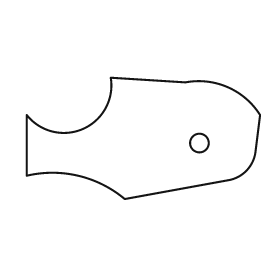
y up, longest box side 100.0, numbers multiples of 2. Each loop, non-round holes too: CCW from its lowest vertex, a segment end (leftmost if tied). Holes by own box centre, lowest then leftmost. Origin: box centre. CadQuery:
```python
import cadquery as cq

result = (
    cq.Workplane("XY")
    .moveTo(-8.0, -26.0)
    .lineTo(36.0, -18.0)
    .threePointArc((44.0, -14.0), (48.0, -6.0))
    .lineTo(50.0, 10.0)
    .threePointArc((36.0, 22.0), (18.0, 24.0))
    .lineTo(-14.0, 26.0)
    .threePointArc((-26.0, 4.0), (-50.0, 10.0))
    .lineTo(-50.0, -16.0)
    .threePointArc((-28.0, -16.0), (-8.0, -26.0))
    .close()
    .moveTo(24.0, -2.0)
    .circle(4.0)
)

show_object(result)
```